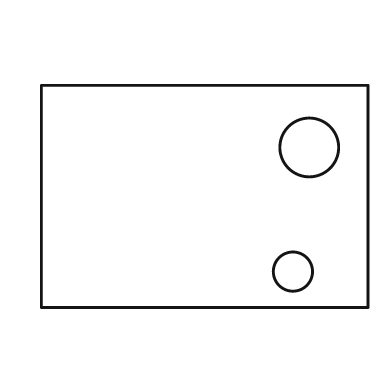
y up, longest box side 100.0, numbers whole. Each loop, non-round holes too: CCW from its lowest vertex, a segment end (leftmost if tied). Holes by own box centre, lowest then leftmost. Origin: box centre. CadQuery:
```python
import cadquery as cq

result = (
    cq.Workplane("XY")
    .moveTo(-50.0, -34.0)
    .lineTo(50.0, -34.0)
    .lineTo(50.0, 34.0)
    .lineTo(-50.0, 34.0)
    .close()
    .moveTo(27.0, -23.0)
    .circle(6.0)
    .moveTo(32.0, 15.0)
    .circle(9.0)
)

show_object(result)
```